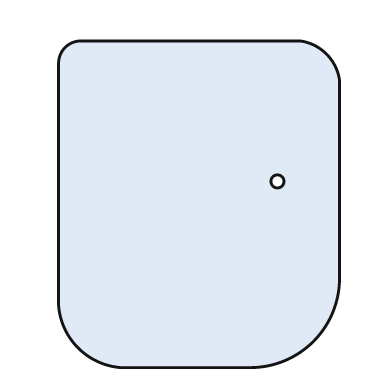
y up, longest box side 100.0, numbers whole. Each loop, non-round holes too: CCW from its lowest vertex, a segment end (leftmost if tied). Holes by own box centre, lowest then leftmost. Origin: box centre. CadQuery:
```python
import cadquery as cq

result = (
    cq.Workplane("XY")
    .moveTo(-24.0, -50.0)
    .lineTo(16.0, -50.0)
    .threePointArc((35.0, -42.0), (43.0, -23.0))
    .lineTo(43.0, 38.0)
    .threePointArc((39.0, 46.0), (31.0, 50.0))
    .lineTo(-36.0, 50.0)
    .threePointArc((-41.0, 48.0), (-43.0, 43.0))
    .lineTo(-43.0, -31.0)
    .threePointArc((-37.0, -44.0), (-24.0, -50.0))
    .close()
    .moveTo(24.0, 7.0)
    .circle(2.0)
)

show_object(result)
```